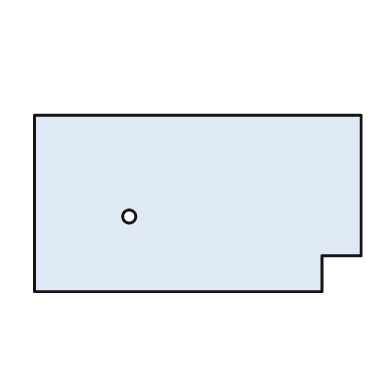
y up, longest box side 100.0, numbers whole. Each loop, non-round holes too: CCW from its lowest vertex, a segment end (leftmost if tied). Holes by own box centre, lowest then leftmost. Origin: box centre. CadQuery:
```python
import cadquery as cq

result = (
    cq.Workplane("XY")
    .moveTo(-50.0, -27.0)
    .lineTo(38.0, -27.0)
    .lineTo(38.0, -16.0)
    .lineTo(50.0, -16.0)
    .lineTo(50.0, 27.0)
    .lineTo(-50.0, 27.0)
    .close()
    .moveTo(-21.0, -4.0)
    .circle(2.0)
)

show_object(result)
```